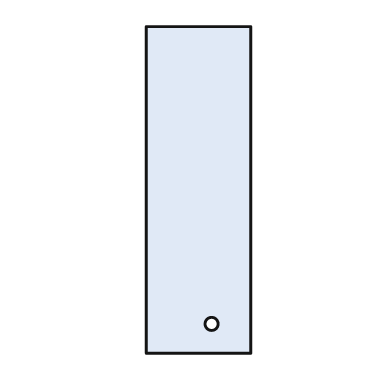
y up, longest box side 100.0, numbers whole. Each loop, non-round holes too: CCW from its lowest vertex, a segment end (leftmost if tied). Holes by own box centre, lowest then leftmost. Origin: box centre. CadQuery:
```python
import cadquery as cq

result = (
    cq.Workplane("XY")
    .moveTo(-16.0, -50.0)
    .lineTo(16.0, -50.0)
    .lineTo(16.0, 50.0)
    .lineTo(-16.0, 50.0)
    .close()
    .moveTo(4.0, -41.0)
    .circle(2.0)
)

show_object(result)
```